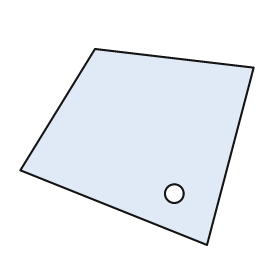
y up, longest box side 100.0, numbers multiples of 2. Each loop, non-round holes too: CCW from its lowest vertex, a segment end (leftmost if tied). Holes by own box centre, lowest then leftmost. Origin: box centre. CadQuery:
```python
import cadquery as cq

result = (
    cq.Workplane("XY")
    .moveTo(30.0, -42.0)
    .lineTo(50.0, 34.0)
    .lineTo(-18.0, 42.0)
    .lineTo(-50.0, -10.0)
    .close()
    .moveTo(16.0, -20.0)
    .circle(4.0)
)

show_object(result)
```